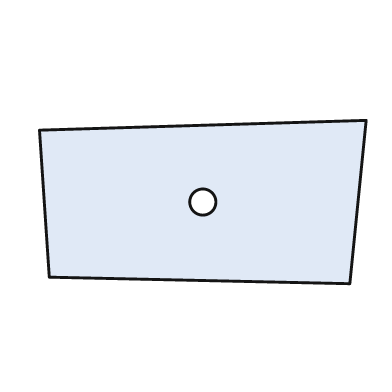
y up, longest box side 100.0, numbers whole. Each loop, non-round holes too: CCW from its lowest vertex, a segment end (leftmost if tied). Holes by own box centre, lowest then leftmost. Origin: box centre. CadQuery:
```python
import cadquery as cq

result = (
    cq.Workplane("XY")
    .moveTo(45.0, -25.0)
    .lineTo(50.0, 25.0)
    .lineTo(-50.0, 22.0)
    .lineTo(-47.0, -23.0)
    .close()
    .moveTo(0.0, 0.0)
    .circle(4.0)
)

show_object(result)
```